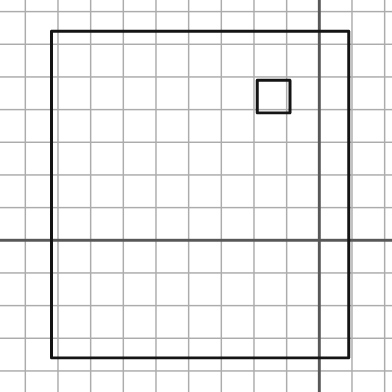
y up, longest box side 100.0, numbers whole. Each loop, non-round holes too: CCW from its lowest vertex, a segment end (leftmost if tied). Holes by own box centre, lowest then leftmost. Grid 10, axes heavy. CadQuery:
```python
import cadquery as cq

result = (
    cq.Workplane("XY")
    .moveTo(-82.0, -36.0)
    .lineTo(9.0, -36.0)
    .lineTo(9.0, 64.0)
    .lineTo(-82.0, 64.0)
    .close()
    .moveTo(-19.0, 39.0)
    .lineTo(-9.0, 39.0)
    .lineTo(-9.0, 49.0)
    .lineTo(-19.0, 49.0)
    .close()
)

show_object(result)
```